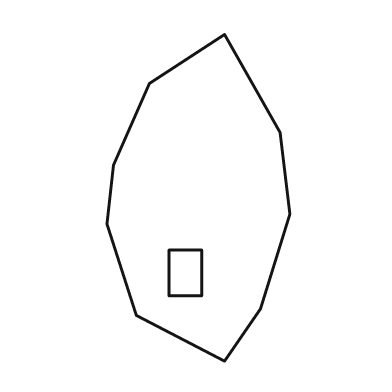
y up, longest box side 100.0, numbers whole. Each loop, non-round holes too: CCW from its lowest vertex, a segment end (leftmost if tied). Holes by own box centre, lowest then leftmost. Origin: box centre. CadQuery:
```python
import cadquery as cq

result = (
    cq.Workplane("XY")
    .moveTo(8.0, -50.0)
    .lineTo(19.0, -34.0)
    .lineTo(28.0, -5.0)
    .lineTo(25.0, 20.0)
    .lineTo(8.0, 50.0)
    .lineTo(-15.0, 35.0)
    .lineTo(-26.0, 10.0)
    .lineTo(-28.0, -8.0)
    .lineTo(-19.0, -36.0)
    .close()
    .moveTo(-9.0, -30.0)
    .lineTo(1.0, -30.0)
    .lineTo(1.0, -16.0)
    .lineTo(-9.0, -16.0)
    .close()
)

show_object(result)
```